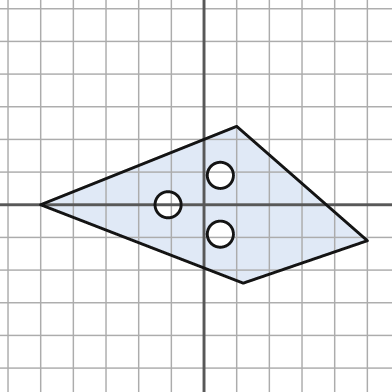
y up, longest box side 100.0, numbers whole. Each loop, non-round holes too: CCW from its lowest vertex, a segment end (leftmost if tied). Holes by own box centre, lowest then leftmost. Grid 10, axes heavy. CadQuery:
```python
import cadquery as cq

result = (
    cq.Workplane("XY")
    .moveTo(12.0, -24.0)
    .lineTo(50.0, -11.0)
    .lineTo(10.0, 24.0)
    .lineTo(-50.0, 0.0)
    .close()
    .moveTo(5.0, -9.0)
    .circle(4.0)
    .moveTo(-11.0, 0.0)
    .circle(4.0)
    .moveTo(5.0, 9.0)
    .circle(4.0)
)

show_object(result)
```